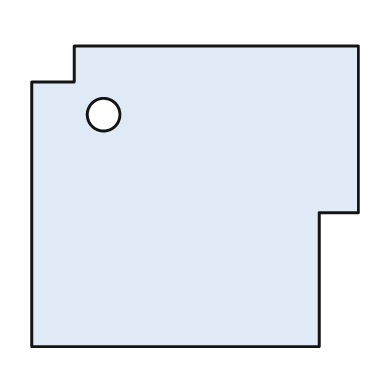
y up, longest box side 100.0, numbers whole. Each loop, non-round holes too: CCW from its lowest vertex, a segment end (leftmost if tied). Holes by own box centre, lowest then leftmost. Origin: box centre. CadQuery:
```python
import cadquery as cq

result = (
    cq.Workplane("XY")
    .moveTo(-50.0, -46.0)
    .lineTo(38.0, -46.0)
    .lineTo(38.0, -5.0)
    .lineTo(50.0, -5.0)
    .lineTo(50.0, 46.0)
    .lineTo(-37.0, 46.0)
    .lineTo(-37.0, 35.0)
    .lineTo(-50.0, 35.0)
    .close()
    .moveTo(-28.0, 25.0)
    .circle(5.0)
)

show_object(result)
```